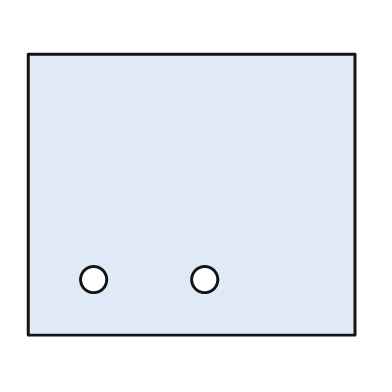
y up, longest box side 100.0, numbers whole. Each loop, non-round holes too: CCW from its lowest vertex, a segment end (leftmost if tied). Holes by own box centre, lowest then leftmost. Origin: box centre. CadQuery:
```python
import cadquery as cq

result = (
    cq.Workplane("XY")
    .moveTo(-50.0, -43.0)
    .lineTo(50.0, -43.0)
    .lineTo(50.0, 43.0)
    .lineTo(-50.0, 43.0)
    .close()
    .moveTo(-30.0, -26.0)
    .circle(4.0)
    .moveTo(4.0, -26.0)
    .circle(4.0)
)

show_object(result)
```